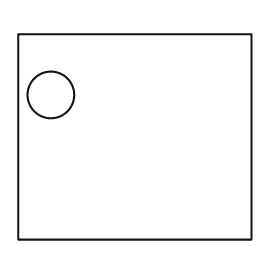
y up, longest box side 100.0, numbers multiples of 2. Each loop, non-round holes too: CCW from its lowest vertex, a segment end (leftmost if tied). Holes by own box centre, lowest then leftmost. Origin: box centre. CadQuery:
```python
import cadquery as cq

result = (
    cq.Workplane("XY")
    .moveTo(-50.0, -44.0)
    .lineTo(50.0, -44.0)
    .lineTo(50.0, 44.0)
    .lineTo(-50.0, 44.0)
    .close()
    .moveTo(-36.0, 18.0)
    .circle(10.0)
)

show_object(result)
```